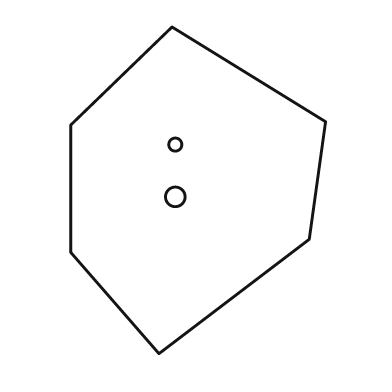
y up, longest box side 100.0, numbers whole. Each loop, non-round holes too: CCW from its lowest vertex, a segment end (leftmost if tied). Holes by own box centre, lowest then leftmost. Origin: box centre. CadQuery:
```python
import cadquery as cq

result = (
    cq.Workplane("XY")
    .moveTo(-12.0, -50.0)
    .lineTo(34.0, -15.0)
    .lineTo(39.0, 21.0)
    .lineTo(-8.0, 50.0)
    .lineTo(-39.0, 20.0)
    .lineTo(-39.0, -19.0)
    .close()
    .moveTo(-7.0, -2.0)
    .circle(3.0)
    .moveTo(-7.0, 14.0)
    .circle(2.0)
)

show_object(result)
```